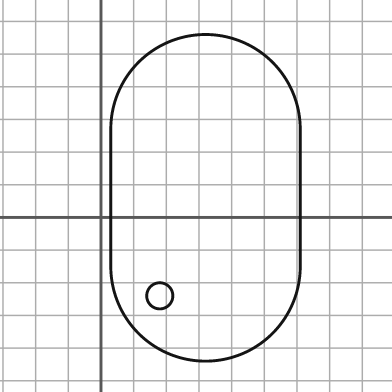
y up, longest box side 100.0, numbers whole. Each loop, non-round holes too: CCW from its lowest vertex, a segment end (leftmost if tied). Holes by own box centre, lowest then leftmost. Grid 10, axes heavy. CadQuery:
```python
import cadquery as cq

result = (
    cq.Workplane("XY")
    .moveTo(3.0, -15.0)
    .threePointArc((32.0, -44.0), (61.0, -15.0))
    .lineTo(61.0, 27.0)
    .threePointArc((32.0, 56.0), (3.0, 27.0))
    .close()
    .moveTo(18.0, -24.0)
    .circle(4.0)
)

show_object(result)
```